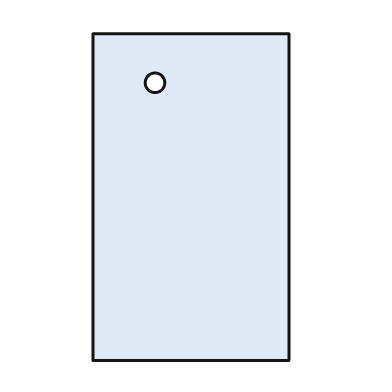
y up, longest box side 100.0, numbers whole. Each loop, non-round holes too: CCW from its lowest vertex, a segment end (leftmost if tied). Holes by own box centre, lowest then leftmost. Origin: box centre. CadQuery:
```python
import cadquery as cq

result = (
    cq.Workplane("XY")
    .moveTo(-30.0, -50.0)
    .lineTo(30.0, -50.0)
    .lineTo(30.0, 50.0)
    .lineTo(-30.0, 50.0)
    .close()
    .moveTo(-11.0, 35.0)
    .circle(3.0)
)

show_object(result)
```